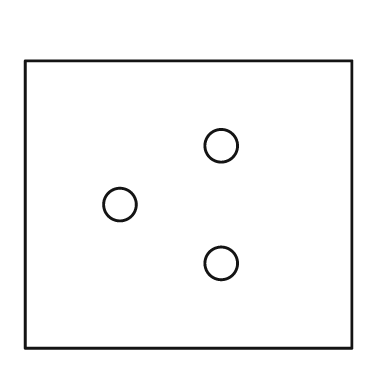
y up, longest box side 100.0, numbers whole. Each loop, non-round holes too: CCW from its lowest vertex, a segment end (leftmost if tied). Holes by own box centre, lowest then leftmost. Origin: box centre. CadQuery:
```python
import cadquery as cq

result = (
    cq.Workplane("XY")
    .moveTo(-50.0, -44.0)
    .lineTo(50.0, -44.0)
    .lineTo(50.0, 44.0)
    .lineTo(-50.0, 44.0)
    .close()
    .moveTo(10.0, -18.0)
    .circle(5.0)
    .moveTo(-21.0, 0.0)
    .circle(5.0)
    .moveTo(10.0, 18.0)
    .circle(5.0)
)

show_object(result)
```